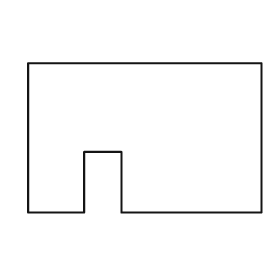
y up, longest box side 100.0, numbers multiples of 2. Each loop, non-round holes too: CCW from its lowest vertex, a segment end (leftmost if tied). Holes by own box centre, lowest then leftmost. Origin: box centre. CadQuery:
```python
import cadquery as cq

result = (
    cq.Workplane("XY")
    .moveTo(-50.0, -32.0)
    .lineTo(-26.0, -32.0)
    .lineTo(-26.0, -6.0)
    .lineTo(-10.0, -6.0)
    .lineTo(-10.0, -32.0)
    .lineTo(50.0, -32.0)
    .lineTo(50.0, 32.0)
    .lineTo(-50.0, 32.0)
    .close()
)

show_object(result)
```